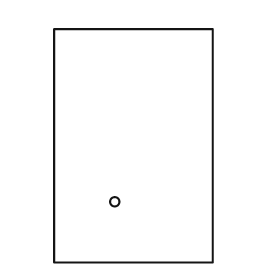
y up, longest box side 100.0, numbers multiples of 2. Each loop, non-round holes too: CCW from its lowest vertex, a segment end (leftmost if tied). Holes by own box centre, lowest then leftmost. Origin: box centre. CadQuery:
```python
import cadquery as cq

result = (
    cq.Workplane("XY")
    .moveTo(-34.0, -50.0)
    .lineTo(34.0, -50.0)
    .lineTo(34.0, 50.0)
    .lineTo(-34.0, 50.0)
    .close()
    .moveTo(-8.0, -24.0)
    .circle(2.0)
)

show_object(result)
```